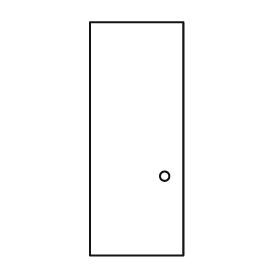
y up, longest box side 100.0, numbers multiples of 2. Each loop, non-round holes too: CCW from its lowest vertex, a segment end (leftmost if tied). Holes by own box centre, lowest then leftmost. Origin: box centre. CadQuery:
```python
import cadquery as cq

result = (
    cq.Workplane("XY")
    .moveTo(-20.0, -50.0)
    .lineTo(20.0, -50.0)
    .lineTo(20.0, 50.0)
    .lineTo(-20.0, 50.0)
    .close()
    .moveTo(12.0, -16.0)
    .circle(2.0)
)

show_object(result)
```